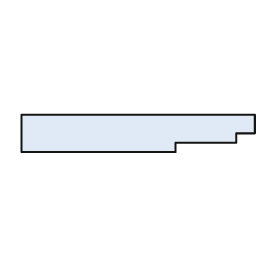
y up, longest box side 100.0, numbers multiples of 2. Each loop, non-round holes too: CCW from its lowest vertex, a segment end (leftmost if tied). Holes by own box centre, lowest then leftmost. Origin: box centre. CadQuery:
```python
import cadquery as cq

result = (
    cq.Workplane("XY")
    .moveTo(-50.0, -8.0)
    .lineTo(16.0, -8.0)
    .lineTo(16.0, -4.0)
    .lineTo(42.0, -4.0)
    .lineTo(42.0, 0.0)
    .lineTo(50.0, 0.0)
    .lineTo(50.0, 8.0)
    .lineTo(-50.0, 8.0)
    .close()
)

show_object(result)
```